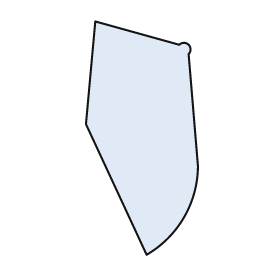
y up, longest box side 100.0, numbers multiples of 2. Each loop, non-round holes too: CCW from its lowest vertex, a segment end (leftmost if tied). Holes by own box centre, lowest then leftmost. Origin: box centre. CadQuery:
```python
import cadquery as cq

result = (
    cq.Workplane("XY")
    .moveTo(2.0, -50.0)
    .threePointArc((18.0, -34.0), (24.0, -12.0))
    .lineTo(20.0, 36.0)
    .threePointArc((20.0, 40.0), (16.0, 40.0))
    .lineTo(-20.0, 50.0)
    .lineTo(-24.0, 6.0)
    .close()
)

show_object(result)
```